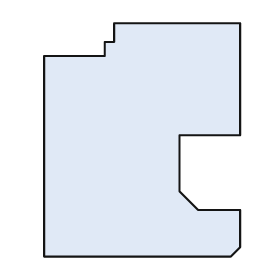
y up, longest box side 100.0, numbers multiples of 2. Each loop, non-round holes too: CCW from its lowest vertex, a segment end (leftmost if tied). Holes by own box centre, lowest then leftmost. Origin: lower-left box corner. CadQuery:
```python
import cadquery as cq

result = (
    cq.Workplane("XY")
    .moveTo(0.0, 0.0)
    .lineTo(80.0, 0.0)
    .lineTo(84.0, 4.0)
    .lineTo(84.0, 20.0)
    .lineTo(66.0, 20.0)
    .lineTo(58.0, 28.0)
    .lineTo(58.0, 52.0)
    .lineTo(84.0, 52.0)
    .lineTo(84.0, 100.0)
    .lineTo(30.0, 100.0)
    .lineTo(30.0, 92.0)
    .lineTo(26.0, 92.0)
    .lineTo(26.0, 86.0)
    .lineTo(0.0, 86.0)
    .close()
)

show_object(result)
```